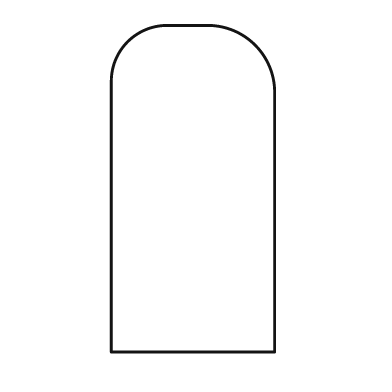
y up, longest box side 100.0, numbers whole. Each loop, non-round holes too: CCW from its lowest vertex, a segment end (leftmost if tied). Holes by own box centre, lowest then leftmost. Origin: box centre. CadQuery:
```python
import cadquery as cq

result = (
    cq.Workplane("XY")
    .moveTo(-25.0, -50.0)
    .lineTo(25.0, -50.0)
    .lineTo(25.0, 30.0)
    .threePointArc((19.0, 44.0), (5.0, 50.0))
    .lineTo(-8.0, 50.0)
    .threePointArc((-20.0, 45.0), (-25.0, 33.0))
    .close()
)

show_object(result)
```